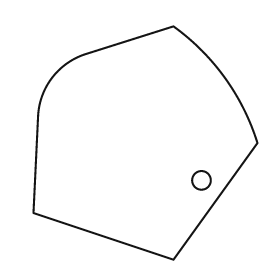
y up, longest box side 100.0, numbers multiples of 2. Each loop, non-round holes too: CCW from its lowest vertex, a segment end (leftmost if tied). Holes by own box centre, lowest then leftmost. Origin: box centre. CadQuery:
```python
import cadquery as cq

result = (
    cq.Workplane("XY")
    .moveTo(12.0, -50.0)
    .lineTo(48.0, 0.0)
    .threePointArc((34.0, 28.0), (12.0, 50.0))
    .lineTo(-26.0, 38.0)
    .threePointArc((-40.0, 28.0), (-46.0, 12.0))
    .lineTo(-48.0, -30.0)
    .close()
    .moveTo(24.0, -16.0)
    .circle(4.0)
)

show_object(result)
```